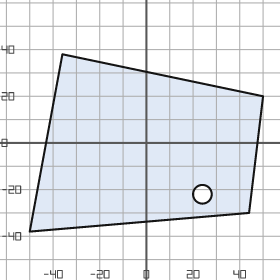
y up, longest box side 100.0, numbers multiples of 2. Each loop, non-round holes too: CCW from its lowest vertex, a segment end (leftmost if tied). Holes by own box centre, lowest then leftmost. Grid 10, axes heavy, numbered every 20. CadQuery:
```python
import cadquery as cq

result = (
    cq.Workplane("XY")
    .moveTo(-50.0, -38.0)
    .lineTo(44.0, -30.0)
    .lineTo(50.0, 20.0)
    .lineTo(-36.0, 38.0)
    .close()
    .moveTo(24.0, -22.0)
    .circle(4.0)
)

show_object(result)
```